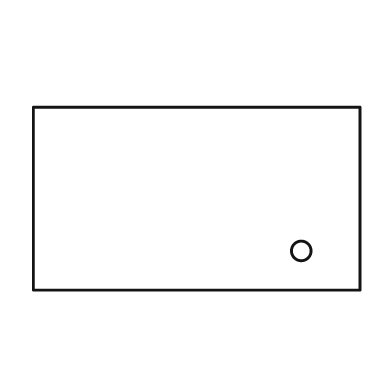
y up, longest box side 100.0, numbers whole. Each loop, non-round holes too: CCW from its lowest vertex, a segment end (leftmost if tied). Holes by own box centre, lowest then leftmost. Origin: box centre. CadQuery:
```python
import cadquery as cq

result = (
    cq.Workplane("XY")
    .moveTo(-50.0, -28.0)
    .lineTo(50.0, -28.0)
    .lineTo(50.0, 28.0)
    .lineTo(-50.0, 28.0)
    .close()
    .moveTo(32.0, -16.0)
    .circle(3.0)
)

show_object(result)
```